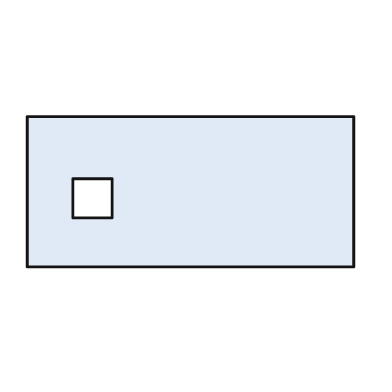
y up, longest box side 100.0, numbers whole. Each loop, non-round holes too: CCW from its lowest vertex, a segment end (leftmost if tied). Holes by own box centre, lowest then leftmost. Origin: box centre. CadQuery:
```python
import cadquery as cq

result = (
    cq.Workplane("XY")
    .moveTo(-50.0, -23.0)
    .lineTo(50.0, -23.0)
    .lineTo(50.0, 23.0)
    .lineTo(-50.0, 23.0)
    .close()
    .moveTo(-36.0, -8.0)
    .lineTo(-24.0, -8.0)
    .lineTo(-24.0, 4.0)
    .lineTo(-36.0, 4.0)
    .close()
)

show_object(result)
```